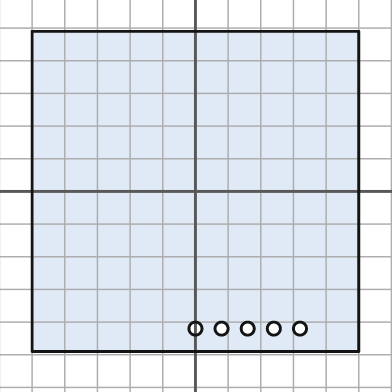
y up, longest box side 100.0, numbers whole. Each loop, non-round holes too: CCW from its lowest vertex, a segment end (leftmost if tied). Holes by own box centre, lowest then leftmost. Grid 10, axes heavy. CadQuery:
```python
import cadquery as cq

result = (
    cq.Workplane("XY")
    .moveTo(-50.0, -49.0)
    .lineTo(50.0, -49.0)
    .lineTo(50.0, 49.0)
    .lineTo(-50.0, 49.0)
    .close()
    .moveTo(0.0, -42.0)
    .circle(2.0)
    .moveTo(8.0, -42.0)
    .circle(2.0)
    .moveTo(16.0, -42.0)
    .circle(2.0)
    .moveTo(24.0, -42.0)
    .circle(2.0)
    .moveTo(32.0, -42.0)
    .circle(2.0)
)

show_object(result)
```